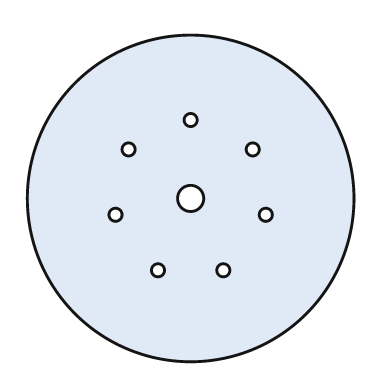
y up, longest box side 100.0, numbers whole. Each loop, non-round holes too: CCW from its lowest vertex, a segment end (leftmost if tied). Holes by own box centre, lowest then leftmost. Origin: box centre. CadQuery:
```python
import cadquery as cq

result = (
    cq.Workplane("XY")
    .moveTo(0.0, 0.0)
    .circle(50.0)
    .moveTo(-10.0, -22.0)
    .circle(2.0)
    .moveTo(10.0, -22.0)
    .circle(2.0)
    .moveTo(-23.0, -5.0)
    .circle(2.0)
    .moveTo(23.0, -5.0)
    .circle(2.0)
    .moveTo(0.0, 0.0)
    .circle(4.0)
    .moveTo(-19.0, 15.0)
    .circle(2.0)
    .moveTo(19.0, 15.0)
    .circle(2.0)
    .moveTo(0.0, 24.0)
    .circle(2.0)
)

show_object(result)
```